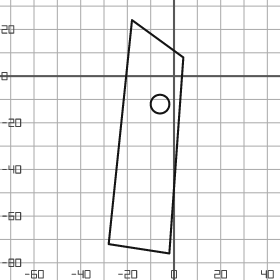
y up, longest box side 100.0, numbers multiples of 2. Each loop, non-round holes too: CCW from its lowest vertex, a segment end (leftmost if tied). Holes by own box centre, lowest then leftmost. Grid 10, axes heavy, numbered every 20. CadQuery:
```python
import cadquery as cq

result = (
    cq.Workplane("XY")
    .moveTo(-2.0, -76.0)
    .lineTo(4.0, 8.0)
    .lineTo(-18.0, 24.0)
    .lineTo(-28.0, -72.0)
    .close()
    .moveTo(-6.0, -12.0)
    .circle(4.0)
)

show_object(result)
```